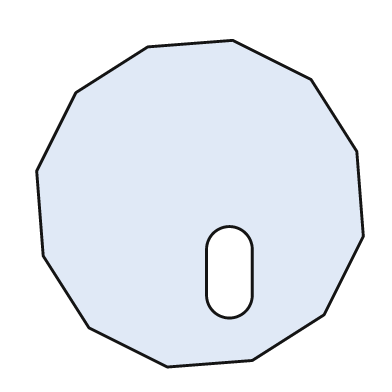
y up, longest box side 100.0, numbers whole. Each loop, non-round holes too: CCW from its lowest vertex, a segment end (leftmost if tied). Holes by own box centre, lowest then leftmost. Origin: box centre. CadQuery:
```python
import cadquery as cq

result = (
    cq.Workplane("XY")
    .moveTo(-10.0, -50.0)
    .lineTo(16.0, -48.0)
    .lineTo(38.0, -34.0)
    .lineTo(50.0, -10.0)
    .lineTo(48.0, 16.0)
    .lineTo(34.0, 38.0)
    .lineTo(10.0, 50.0)
    .lineTo(-16.0, 48.0)
    .lineTo(-38.0, 34.0)
    .lineTo(-50.0, 10.0)
    .lineTo(-48.0, -16.0)
    .lineTo(-34.0, -38.0)
    .close()
    .moveTo(2.0, -28.0)
    .threePointArc((9.0, -35.0), (16.0, -28.0))
    .lineTo(16.0, -14.0)
    .threePointArc((9.0, -7.0), (2.0, -14.0))
    .close()
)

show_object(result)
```